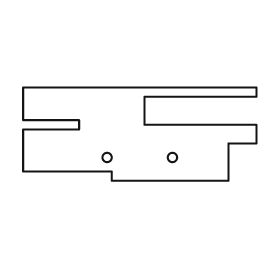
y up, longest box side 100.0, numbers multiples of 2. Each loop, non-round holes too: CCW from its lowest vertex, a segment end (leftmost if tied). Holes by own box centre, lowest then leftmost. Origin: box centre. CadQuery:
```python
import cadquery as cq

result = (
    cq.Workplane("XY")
    .moveTo(-12.0, -20.0)
    .lineTo(38.0, -20.0)
    .lineTo(38.0, -4.0)
    .lineTo(50.0, -4.0)
    .lineTo(50.0, 4.0)
    .lineTo(2.0, 4.0)
    .lineTo(2.0, 16.0)
    .lineTo(50.0, 16.0)
    .lineTo(50.0, 20.0)
    .lineTo(-50.0, 20.0)
    .lineTo(-50.0, 6.0)
    .lineTo(-26.0, 6.0)
    .lineTo(-26.0, 2.0)
    .lineTo(-50.0, 2.0)
    .lineTo(-50.0, -16.0)
    .lineTo(-12.0, -16.0)
    .close()
    .moveTo(-14.0, -10.0)
    .circle(2.0)
    .moveTo(14.0, -10.0)
    .circle(2.0)
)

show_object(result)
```